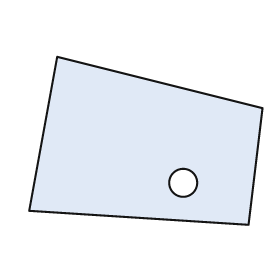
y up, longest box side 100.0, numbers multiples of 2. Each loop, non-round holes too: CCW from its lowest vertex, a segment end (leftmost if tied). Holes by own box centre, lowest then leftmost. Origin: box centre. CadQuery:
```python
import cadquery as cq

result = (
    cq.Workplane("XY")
    .moveTo(44.0, -36.0)
    .lineTo(50.0, 14.0)
    .lineTo(-38.0, 36.0)
    .lineTo(-50.0, -30.0)
    .close()
    .moveTo(16.0, -18.0)
    .circle(6.0)
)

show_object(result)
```